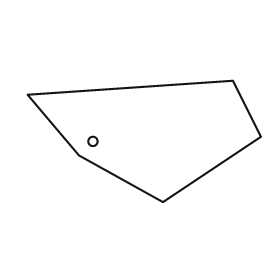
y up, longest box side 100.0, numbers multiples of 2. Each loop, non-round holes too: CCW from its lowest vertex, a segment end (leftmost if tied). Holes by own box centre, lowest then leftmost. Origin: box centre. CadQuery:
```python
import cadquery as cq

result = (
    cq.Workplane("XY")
    .moveTo(8.0, -26.0)
    .lineTo(50.0, 2.0)
    .lineTo(38.0, 26.0)
    .lineTo(-50.0, 20.0)
    .lineTo(-28.0, -6.0)
    .close()
    .moveTo(-22.0, 0.0)
    .circle(2.0)
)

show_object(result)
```